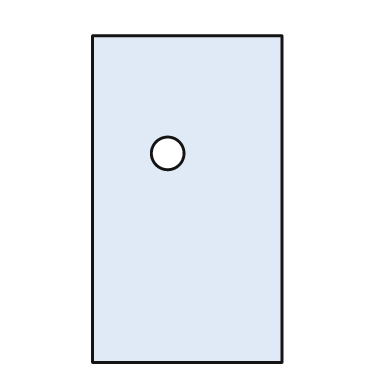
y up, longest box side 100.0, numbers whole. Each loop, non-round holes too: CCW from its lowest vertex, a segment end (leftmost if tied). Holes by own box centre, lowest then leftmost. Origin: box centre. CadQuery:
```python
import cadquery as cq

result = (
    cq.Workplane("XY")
    .moveTo(-29.0, -50.0)
    .lineTo(29.0, -50.0)
    .lineTo(29.0, 50.0)
    .lineTo(-29.0, 50.0)
    .close()
    .moveTo(-6.0, 14.0)
    .circle(5.0)
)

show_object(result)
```